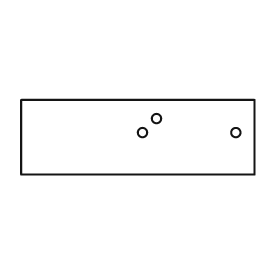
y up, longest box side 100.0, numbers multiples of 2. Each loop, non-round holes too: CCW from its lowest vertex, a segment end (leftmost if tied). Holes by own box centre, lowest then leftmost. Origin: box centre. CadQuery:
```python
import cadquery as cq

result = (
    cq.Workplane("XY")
    .moveTo(-50.0, -16.0)
    .lineTo(50.0, -16.0)
    .lineTo(50.0, 16.0)
    .lineTo(-50.0, 16.0)
    .close()
    .moveTo(2.0, 2.0)
    .circle(2.0)
    .moveTo(42.0, 2.0)
    .circle(2.0)
    .moveTo(8.0, 8.0)
    .circle(2.0)
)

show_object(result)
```